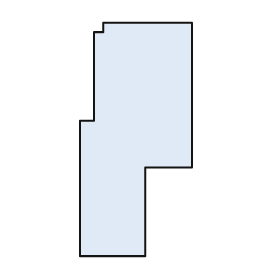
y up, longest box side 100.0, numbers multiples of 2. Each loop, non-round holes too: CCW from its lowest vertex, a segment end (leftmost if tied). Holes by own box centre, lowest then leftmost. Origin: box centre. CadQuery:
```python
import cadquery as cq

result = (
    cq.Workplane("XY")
    .moveTo(-24.0, -50.0)
    .lineTo(4.0, -50.0)
    .lineTo(4.0, -12.0)
    .lineTo(24.0, -12.0)
    .lineTo(24.0, 50.0)
    .lineTo(-14.0, 50.0)
    .lineTo(-14.0, 46.0)
    .lineTo(-18.0, 46.0)
    .lineTo(-18.0, 8.0)
    .lineTo(-24.0, 8.0)
    .close()
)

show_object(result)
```